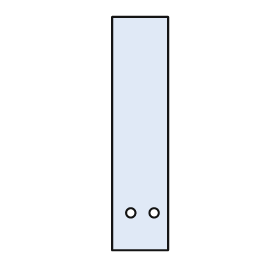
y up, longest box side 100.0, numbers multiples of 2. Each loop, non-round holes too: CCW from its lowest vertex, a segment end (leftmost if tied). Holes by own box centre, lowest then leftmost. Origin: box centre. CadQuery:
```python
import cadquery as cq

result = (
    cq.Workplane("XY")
    .moveTo(-12.0, -50.0)
    .lineTo(12.0, -50.0)
    .lineTo(12.0, 50.0)
    .lineTo(-12.0, 50.0)
    .close()
    .moveTo(-4.0, -34.0)
    .circle(2.0)
    .moveTo(6.0, -34.0)
    .circle(2.0)
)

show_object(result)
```